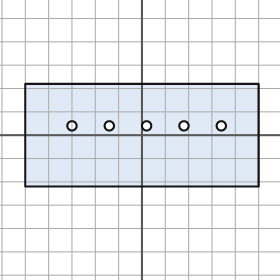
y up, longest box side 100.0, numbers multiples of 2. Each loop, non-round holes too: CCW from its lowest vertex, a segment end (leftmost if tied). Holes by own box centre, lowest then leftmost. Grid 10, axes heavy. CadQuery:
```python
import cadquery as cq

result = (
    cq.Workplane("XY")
    .moveTo(-50.0, -22.0)
    .lineTo(50.0, -22.0)
    .lineTo(50.0, 22.0)
    .lineTo(-50.0, 22.0)
    .close()
    .moveTo(-30.0, 4.0)
    .circle(2.0)
    .moveTo(-14.0, 4.0)
    .circle(2.0)
    .moveTo(2.0, 4.0)
    .circle(2.0)
    .moveTo(18.0, 4.0)
    .circle(2.0)
    .moveTo(34.0, 4.0)
    .circle(2.0)
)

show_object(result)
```